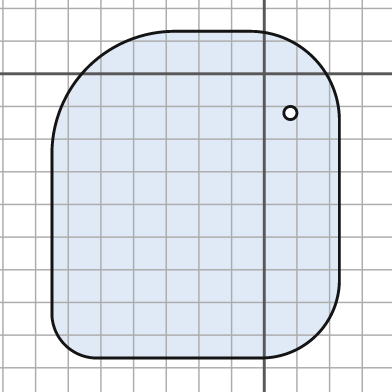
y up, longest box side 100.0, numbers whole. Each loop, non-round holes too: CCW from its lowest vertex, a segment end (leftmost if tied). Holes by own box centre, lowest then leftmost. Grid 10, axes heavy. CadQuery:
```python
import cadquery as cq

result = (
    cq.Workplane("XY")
    .moveTo(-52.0, -87.0)
    .lineTo(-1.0, -87.0)
    .threePointArc((16.0, -80.0), (23.0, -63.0))
    .lineTo(23.0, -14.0)
    .threePointArc((15.0, 5.0), (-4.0, 13.0))
    .lineTo(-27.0, 13.0)
    .threePointArc((-54.0, 2.0), (-65.0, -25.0))
    .lineTo(-65.0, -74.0)
    .threePointArc((-61.0, -83.0), (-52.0, -87.0))
    .close()
    .moveTo(8.0, -12.0)
    .circle(2.0)
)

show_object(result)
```